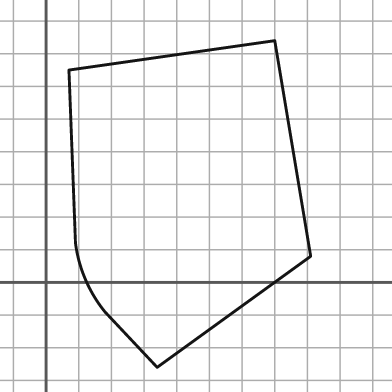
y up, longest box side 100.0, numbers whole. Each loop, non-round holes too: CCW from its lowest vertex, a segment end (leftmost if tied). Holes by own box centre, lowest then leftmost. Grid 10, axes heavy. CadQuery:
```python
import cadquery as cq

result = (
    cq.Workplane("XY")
    .moveTo(34.0, -26.0)
    .lineTo(81.0, 8.0)
    .lineTo(70.0, 74.0)
    .lineTo(7.0, 65.0)
    .lineTo(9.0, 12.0)
    .threePointArc((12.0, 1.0), (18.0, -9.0))
    .close()
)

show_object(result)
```